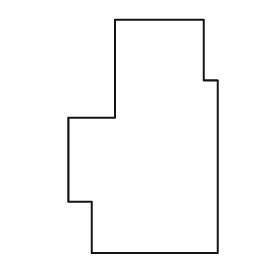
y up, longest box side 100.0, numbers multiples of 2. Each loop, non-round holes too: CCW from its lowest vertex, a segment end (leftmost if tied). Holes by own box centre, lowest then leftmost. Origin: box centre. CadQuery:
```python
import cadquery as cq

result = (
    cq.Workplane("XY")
    .moveTo(-22.0, -50.0)
    .lineTo(32.0, -50.0)
    .lineTo(32.0, 24.0)
    .lineTo(26.0, 24.0)
    .lineTo(26.0, 50.0)
    .lineTo(-12.0, 50.0)
    .lineTo(-12.0, 8.0)
    .lineTo(-32.0, 8.0)
    .lineTo(-32.0, -28.0)
    .lineTo(-22.0, -28.0)
    .close()
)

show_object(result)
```